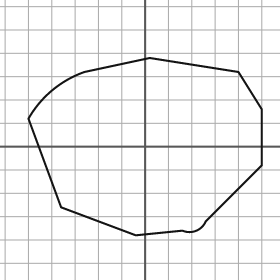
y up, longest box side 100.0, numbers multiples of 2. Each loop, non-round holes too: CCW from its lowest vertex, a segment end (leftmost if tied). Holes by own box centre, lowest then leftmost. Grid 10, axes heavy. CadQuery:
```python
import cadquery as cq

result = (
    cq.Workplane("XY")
    .moveTo(-4.0, -38.0)
    .lineTo(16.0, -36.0)
    .threePointArc((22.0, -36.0), (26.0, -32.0))
    .lineTo(50.0, -8.0)
    .lineTo(50.0, 16.0)
    .lineTo(40.0, 32.0)
    .lineTo(2.0, 38.0)
    .lineTo(-26.0, 32.0)
    .threePointArc((-40.0, 24.0), (-50.0, 12.0))
    .lineTo(-36.0, -26.0)
    .close()
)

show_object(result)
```